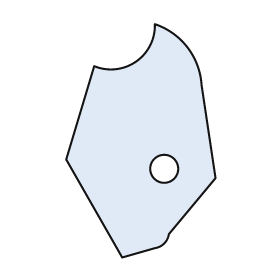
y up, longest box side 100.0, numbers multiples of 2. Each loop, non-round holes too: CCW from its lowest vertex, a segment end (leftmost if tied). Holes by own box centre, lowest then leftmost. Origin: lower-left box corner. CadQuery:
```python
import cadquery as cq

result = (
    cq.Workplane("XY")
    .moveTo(24.0, 0.0)
    .lineTo(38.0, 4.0)
    .threePointArc((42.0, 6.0), (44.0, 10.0))
    .lineTo(64.0, 34.0)
    .lineTo(58.0, 74.0)
    .threePointArc((52.0, 90.0), (38.0, 100.0))
    .threePointArc((30.0, 84.0), (12.0, 82.0))
    .lineTo(0.0, 42.0)
    .close()
    .moveTo(42.0, 38.0)
    .circle(6.0)
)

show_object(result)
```